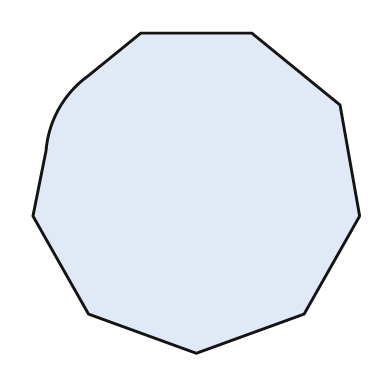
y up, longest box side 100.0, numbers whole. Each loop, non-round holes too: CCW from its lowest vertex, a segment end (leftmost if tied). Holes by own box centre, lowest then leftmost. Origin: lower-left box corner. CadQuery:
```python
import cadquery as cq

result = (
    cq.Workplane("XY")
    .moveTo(50.0, 0.0)
    .lineTo(83.0, 12.0)
    .lineTo(100.0, 42.0)
    .lineTo(94.0, 76.0)
    .lineTo(67.0, 98.0)
    .lineTo(33.0, 98.0)
    .lineTo(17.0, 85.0)
    .threePointArc((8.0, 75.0), (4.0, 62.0))
    .lineTo(0.0, 42.0)
    .lineTo(17.0, 12.0)
    .close()
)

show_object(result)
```